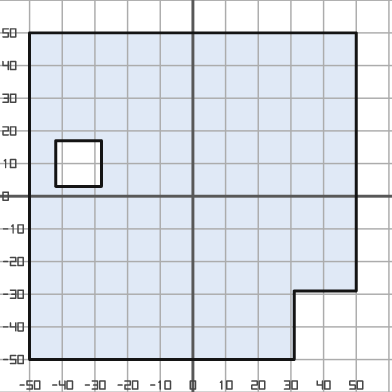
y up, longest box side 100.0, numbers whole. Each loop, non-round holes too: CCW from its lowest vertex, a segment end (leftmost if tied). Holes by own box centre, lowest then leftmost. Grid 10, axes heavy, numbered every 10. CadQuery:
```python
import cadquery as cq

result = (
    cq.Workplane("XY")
    .moveTo(-50.0, -50.0)
    .lineTo(31.0, -50.0)
    .lineTo(31.0, -29.0)
    .lineTo(50.0, -29.0)
    .lineTo(50.0, 50.0)
    .lineTo(-50.0, 50.0)
    .close()
    .moveTo(-42.0, 3.0)
    .lineTo(-28.0, 3.0)
    .lineTo(-28.0, 17.0)
    .lineTo(-42.0, 17.0)
    .close()
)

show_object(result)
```